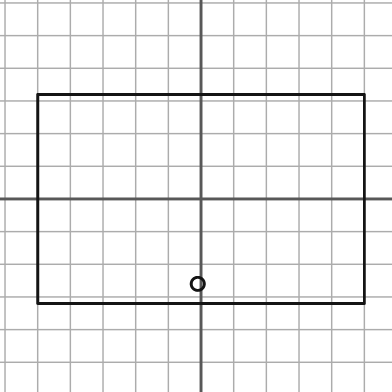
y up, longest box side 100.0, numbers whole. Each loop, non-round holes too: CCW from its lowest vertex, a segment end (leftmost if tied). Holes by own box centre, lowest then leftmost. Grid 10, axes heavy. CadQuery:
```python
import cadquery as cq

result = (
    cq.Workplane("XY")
    .moveTo(-50.0, -32.0)
    .lineTo(50.0, -32.0)
    .lineTo(50.0, 32.0)
    .lineTo(-50.0, 32.0)
    .close()
    .moveTo(-1.0, -26.0)
    .circle(2.0)
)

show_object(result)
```